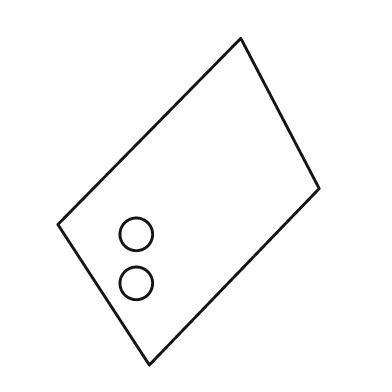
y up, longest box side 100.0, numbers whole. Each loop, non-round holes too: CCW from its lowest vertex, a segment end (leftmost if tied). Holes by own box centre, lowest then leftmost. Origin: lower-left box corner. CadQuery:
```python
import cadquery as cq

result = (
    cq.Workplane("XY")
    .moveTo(28.0, 0.0)
    .lineTo(80.0, 54.0)
    .lineTo(56.0, 100.0)
    .lineTo(0.0, 43.0)
    .close()
    .moveTo(24.0, 25.0)
    .circle(5.0)
    .moveTo(24.0, 40.0)
    .circle(5.0)
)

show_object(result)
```